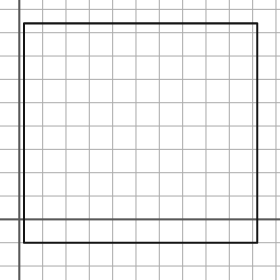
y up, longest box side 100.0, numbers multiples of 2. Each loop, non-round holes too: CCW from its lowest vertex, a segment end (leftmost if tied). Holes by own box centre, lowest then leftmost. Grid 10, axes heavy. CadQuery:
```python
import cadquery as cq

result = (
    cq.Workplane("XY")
    .moveTo(2.0, -10.0)
    .lineTo(102.0, -10.0)
    .lineTo(102.0, 84.0)
    .lineTo(2.0, 84.0)
    .close()
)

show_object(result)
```